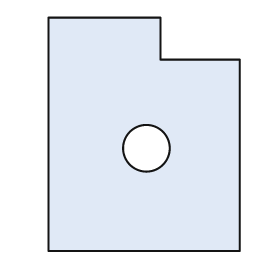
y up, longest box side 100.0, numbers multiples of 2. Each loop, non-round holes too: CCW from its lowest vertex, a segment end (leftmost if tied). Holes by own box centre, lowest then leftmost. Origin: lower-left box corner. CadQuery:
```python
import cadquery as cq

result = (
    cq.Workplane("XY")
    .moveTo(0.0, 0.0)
    .lineTo(82.0, 0.0)
    .lineTo(82.0, 82.0)
    .lineTo(48.0, 82.0)
    .lineTo(48.0, 100.0)
    .lineTo(0.0, 100.0)
    .close()
    .moveTo(42.0, 44.0)
    .circle(10.0)
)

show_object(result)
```